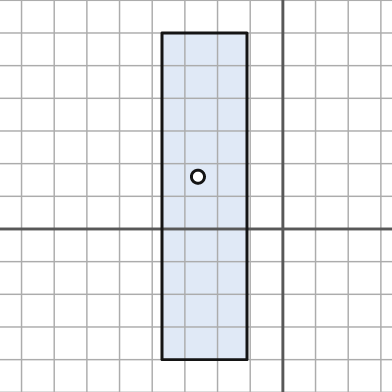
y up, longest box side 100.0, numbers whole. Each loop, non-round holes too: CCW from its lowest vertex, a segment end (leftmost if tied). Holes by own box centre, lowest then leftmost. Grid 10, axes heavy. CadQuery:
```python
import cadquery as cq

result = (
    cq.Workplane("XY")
    .moveTo(-37.0, -40.0)
    .lineTo(-11.0, -40.0)
    .lineTo(-11.0, 60.0)
    .lineTo(-37.0, 60.0)
    .close()
    .moveTo(-26.0, 16.0)
    .circle(2.0)
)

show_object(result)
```